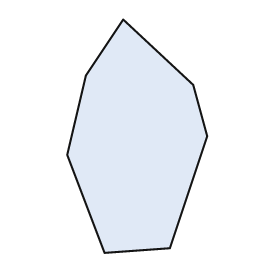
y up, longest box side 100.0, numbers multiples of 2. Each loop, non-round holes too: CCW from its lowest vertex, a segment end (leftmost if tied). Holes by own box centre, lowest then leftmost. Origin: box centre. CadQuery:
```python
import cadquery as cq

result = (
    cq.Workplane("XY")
    .moveTo(-14.0, -50.0)
    .lineTo(14.0, -48.0)
    .lineTo(30.0, 0.0)
    .lineTo(24.0, 22.0)
    .lineTo(-6.0, 50.0)
    .lineTo(-22.0, 26.0)
    .lineTo(-30.0, -8.0)
    .close()
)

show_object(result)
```